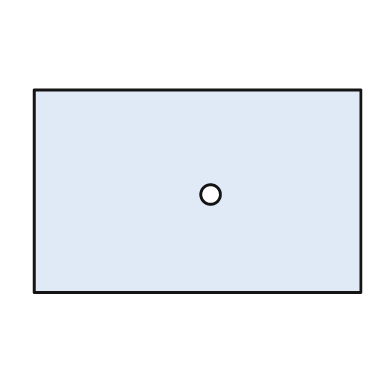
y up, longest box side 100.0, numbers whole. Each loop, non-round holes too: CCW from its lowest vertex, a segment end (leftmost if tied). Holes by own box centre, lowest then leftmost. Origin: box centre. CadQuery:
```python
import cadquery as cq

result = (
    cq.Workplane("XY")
    .moveTo(-50.0, -31.0)
    .lineTo(50.0, -31.0)
    .lineTo(50.0, 31.0)
    .lineTo(-50.0, 31.0)
    .close()
    .moveTo(4.0, -1.0)
    .circle(3.0)
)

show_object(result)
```